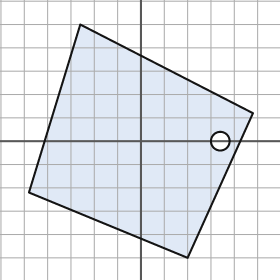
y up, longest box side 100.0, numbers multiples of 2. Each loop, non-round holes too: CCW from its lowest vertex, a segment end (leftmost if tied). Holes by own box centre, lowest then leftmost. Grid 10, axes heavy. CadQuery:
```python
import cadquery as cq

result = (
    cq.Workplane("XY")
    .moveTo(20.0, -50.0)
    .lineTo(48.0, 12.0)
    .lineTo(-26.0, 50.0)
    .lineTo(-48.0, -22.0)
    .close()
    .moveTo(34.0, 0.0)
    .circle(4.0)
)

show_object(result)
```